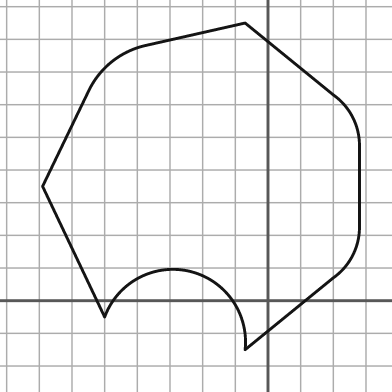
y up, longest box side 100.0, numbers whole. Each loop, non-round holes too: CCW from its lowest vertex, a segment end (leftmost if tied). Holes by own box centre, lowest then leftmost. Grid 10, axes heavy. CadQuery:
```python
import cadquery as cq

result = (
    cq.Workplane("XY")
    .moveTo(-7.0, -15.0)
    .lineTo(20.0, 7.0)
    .threePointArc((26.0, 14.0), (28.0, 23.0))
    .lineTo(28.0, 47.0)
    .threePointArc((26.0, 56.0), (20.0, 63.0))
    .lineTo(-7.0, 85.0)
    .lineTo(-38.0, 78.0)
    .threePointArc((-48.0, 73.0), (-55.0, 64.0))
    .lineTo(-69.0, 35.0)
    .lineTo(-50.0, -5.0)
    .threePointArc((-24.0, 9.0), (-7.0, -15.0))
    .close()
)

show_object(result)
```